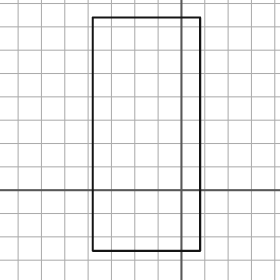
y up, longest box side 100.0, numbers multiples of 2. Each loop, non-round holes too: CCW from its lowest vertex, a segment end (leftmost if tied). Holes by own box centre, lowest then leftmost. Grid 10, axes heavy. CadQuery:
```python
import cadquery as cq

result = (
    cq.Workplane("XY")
    .moveTo(-38.0, -26.0)
    .lineTo(8.0, -26.0)
    .lineTo(8.0, 74.0)
    .lineTo(-38.0, 74.0)
    .close()
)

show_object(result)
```